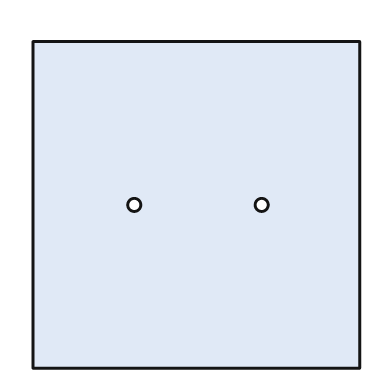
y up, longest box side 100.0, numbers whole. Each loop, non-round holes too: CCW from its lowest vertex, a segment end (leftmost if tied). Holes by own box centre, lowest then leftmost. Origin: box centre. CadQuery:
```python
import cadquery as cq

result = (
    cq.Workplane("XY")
    .moveTo(-50.0, -50.0)
    .lineTo(50.0, -50.0)
    .lineTo(50.0, 50.0)
    .lineTo(-50.0, 50.0)
    .close()
    .moveTo(-19.0, 0.0)
    .circle(2.0)
    .moveTo(20.0, 0.0)
    .circle(2.0)
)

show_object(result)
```